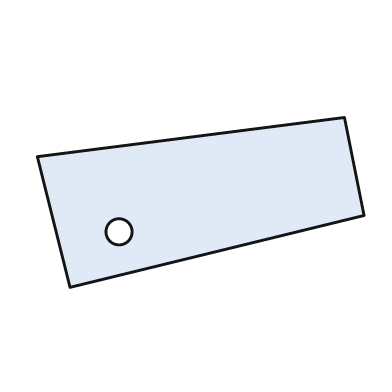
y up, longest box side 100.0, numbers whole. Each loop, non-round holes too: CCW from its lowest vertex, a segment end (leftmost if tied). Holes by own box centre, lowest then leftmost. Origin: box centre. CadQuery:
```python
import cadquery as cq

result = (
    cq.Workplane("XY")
    .moveTo(-40.0, -26.0)
    .lineTo(50.0, -4.0)
    .lineTo(44.0, 26.0)
    .lineTo(-50.0, 14.0)
    .close()
    .moveTo(-25.0, -9.0)
    .circle(4.0)
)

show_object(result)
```